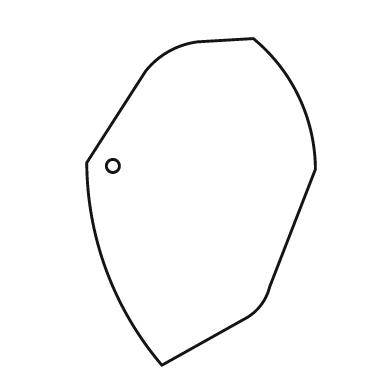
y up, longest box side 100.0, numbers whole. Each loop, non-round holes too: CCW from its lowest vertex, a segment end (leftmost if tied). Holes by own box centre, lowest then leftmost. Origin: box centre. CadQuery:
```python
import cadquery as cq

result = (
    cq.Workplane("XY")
    .moveTo(-12.0, -50.0)
    .lineTo(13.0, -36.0)
    .threePointArc((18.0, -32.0), (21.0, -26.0))
    .lineTo(35.0, 10.0)
    .threePointArc((30.0, 32.0), (16.0, 50.0))
    .lineTo(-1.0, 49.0)
    .threePointArc((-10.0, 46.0), (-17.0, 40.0))
    .lineTo(-35.0, 12.0)
    .threePointArc((-29.0, -21.0), (-12.0, -50.0))
    .close()
    .moveTo(-27.0, 11.0)
    .circle(2.0)
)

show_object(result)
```